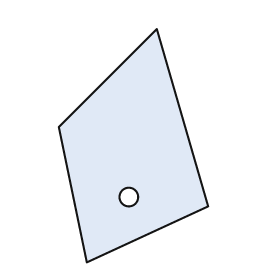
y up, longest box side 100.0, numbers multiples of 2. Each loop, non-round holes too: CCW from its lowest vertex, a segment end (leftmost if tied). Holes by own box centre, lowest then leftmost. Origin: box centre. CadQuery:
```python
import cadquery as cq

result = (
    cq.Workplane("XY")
    .moveTo(-20.0, -50.0)
    .lineTo(32.0, -26.0)
    .lineTo(10.0, 50.0)
    .lineTo(-32.0, 8.0)
    .close()
    .moveTo(-2.0, -22.0)
    .circle(4.0)
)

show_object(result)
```